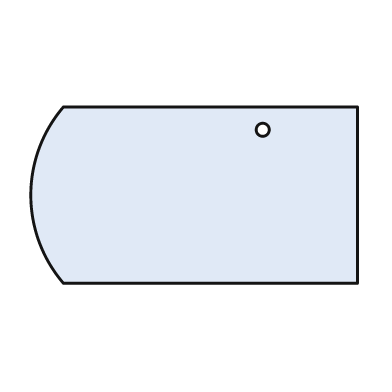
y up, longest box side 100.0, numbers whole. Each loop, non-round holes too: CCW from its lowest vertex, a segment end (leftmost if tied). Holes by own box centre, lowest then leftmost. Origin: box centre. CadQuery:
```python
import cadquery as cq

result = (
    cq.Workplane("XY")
    .moveTo(-40.0, -27.0)
    .lineTo(50.0, -27.0)
    .lineTo(50.0, 27.0)
    .lineTo(-40.0, 27.0)
    .threePointArc((-50.0, 0.0), (-40.0, -27.0))
    .close()
    .moveTo(21.0, 20.0)
    .circle(2.0)
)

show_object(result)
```